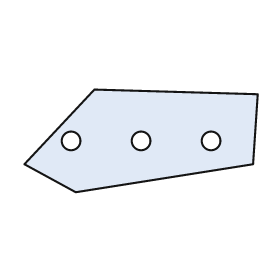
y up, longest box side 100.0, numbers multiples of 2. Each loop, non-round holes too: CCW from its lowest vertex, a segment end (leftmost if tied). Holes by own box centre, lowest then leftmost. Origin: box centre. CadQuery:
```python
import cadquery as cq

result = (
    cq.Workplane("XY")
    .moveTo(-28.0, -22.0)
    .lineTo(48.0, -10.0)
    .lineTo(50.0, 20.0)
    .lineTo(-20.0, 22.0)
    .lineTo(-50.0, -10.0)
    .close()
    .moveTo(-30.0, 0.0)
    .circle(4.0)
    .moveTo(0.0, 0.0)
    .circle(4.0)
    .moveTo(30.0, 0.0)
    .circle(4.0)
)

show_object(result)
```